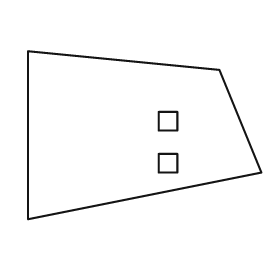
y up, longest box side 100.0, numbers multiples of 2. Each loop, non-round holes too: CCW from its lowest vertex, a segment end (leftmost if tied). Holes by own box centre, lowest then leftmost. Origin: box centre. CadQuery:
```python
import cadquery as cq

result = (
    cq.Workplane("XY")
    .moveTo(-50.0, -36.0)
    .lineTo(50.0, -16.0)
    .lineTo(32.0, 28.0)
    .lineTo(-50.0, 36.0)
    .close()
    .moveTo(6.0, -16.0)
    .lineTo(14.0, -16.0)
    .lineTo(14.0, -8.0)
    .lineTo(6.0, -8.0)
    .close()
    .moveTo(6.0, 2.0)
    .lineTo(14.0, 2.0)
    .lineTo(14.0, 10.0)
    .lineTo(6.0, 10.0)
    .close()
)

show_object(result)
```